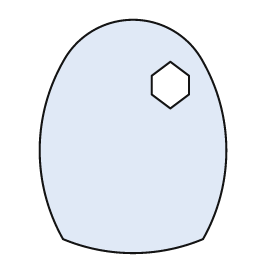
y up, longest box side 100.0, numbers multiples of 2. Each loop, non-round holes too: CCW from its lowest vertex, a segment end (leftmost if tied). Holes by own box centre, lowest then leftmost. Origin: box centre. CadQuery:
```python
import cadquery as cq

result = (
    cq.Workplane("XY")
    .moveTo(-30.0, -44.0)
    .threePointArc((0.0, -50.0), (30.0, -44.0))
    .threePointArc((40.0, -6.0), (30.0, 32.0))
    .threePointArc((0.0, 50.0), (-30.0, 32.0))
    .threePointArc((-40.0, -6.0), (-30.0, -44.0))
    .close()
    .moveTo(16.0, 12.0)
    .lineTo(24.0, 18.0)
    .lineTo(24.0, 26.0)
    .lineTo(16.0, 32.0)
    .lineTo(8.0, 26.0)
    .lineTo(8.0, 18.0)
    .close()
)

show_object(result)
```